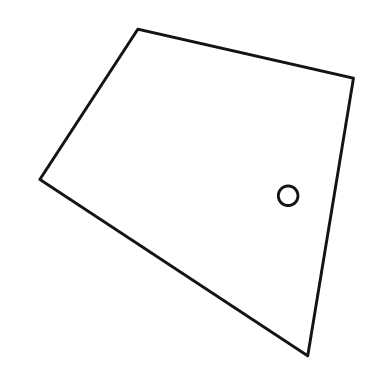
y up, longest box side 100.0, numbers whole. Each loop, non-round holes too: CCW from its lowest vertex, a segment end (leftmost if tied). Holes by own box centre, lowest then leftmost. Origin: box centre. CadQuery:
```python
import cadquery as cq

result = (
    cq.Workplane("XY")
    .moveTo(34.0, -50.0)
    .lineTo(48.0, 35.0)
    .lineTo(-18.0, 50.0)
    .lineTo(-48.0, 4.0)
    .close()
    .moveTo(28.0, -1.0)
    .circle(3.0)
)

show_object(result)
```